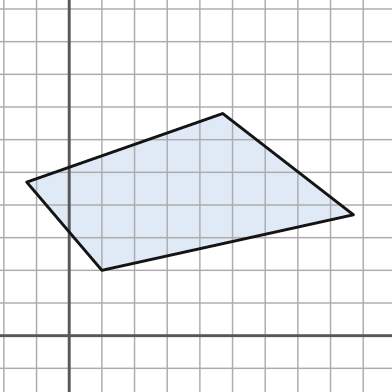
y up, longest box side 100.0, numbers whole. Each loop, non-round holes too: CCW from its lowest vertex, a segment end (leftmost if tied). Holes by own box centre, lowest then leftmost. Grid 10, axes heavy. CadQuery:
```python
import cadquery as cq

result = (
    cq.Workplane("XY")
    .moveTo(10.0, 20.0)
    .lineTo(87.0, 37.0)
    .lineTo(47.0, 68.0)
    .lineTo(-13.0, 47.0)
    .close()
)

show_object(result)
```